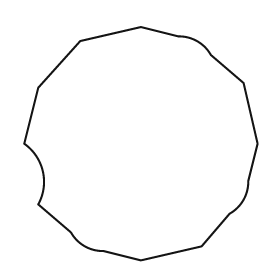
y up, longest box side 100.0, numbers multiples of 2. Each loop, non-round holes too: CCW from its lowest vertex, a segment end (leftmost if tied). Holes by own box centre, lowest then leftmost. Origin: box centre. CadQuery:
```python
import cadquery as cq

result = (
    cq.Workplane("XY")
    .moveTo(0.0, -50.0)
    .lineTo(26.0, -44.0)
    .lineTo(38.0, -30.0)
    .threePointArc((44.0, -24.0), (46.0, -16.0))
    .lineTo(50.0, 0.0)
    .lineTo(44.0, 26.0)
    .lineTo(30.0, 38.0)
    .threePointArc((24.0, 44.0), (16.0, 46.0))
    .lineTo(0.0, 50.0)
    .lineTo(-26.0, 44.0)
    .lineTo(-44.0, 24.0)
    .lineTo(-50.0, 0.0)
    .threePointArc((-42.0, -12.0), (-44.0, -26.0))
    .lineTo(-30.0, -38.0)
    .threePointArc((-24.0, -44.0), (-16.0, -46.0))
    .close()
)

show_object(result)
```